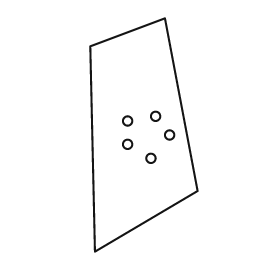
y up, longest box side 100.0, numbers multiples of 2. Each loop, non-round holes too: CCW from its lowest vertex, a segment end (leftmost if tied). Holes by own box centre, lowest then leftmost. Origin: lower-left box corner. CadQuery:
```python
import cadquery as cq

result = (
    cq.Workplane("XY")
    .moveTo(2.0, 0.0)
    .lineTo(46.0, 26.0)
    .lineTo(32.0, 100.0)
    .lineTo(0.0, 88.0)
    .close()
    .moveTo(26.0, 40.0)
    .circle(2.0)
    .moveTo(16.0, 46.0)
    .circle(2.0)
    .moveTo(34.0, 50.0)
    .circle(2.0)
    .moveTo(16.0, 56.0)
    .circle(2.0)
    .moveTo(28.0, 58.0)
    .circle(2.0)
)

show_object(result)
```